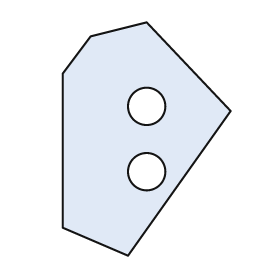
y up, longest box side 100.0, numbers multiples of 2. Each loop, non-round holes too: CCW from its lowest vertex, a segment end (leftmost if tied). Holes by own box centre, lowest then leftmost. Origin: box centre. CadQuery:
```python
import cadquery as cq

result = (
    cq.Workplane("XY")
    .moveTo(-8.0, -50.0)
    .lineTo(36.0, 12.0)
    .lineTo(0.0, 50.0)
    .lineTo(-24.0, 44.0)
    .lineTo(-36.0, 28.0)
    .lineTo(-36.0, -38.0)
    .close()
    .moveTo(0.0, -14.0)
    .circle(8.0)
    .moveTo(0.0, 14.0)
    .circle(8.0)
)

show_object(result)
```